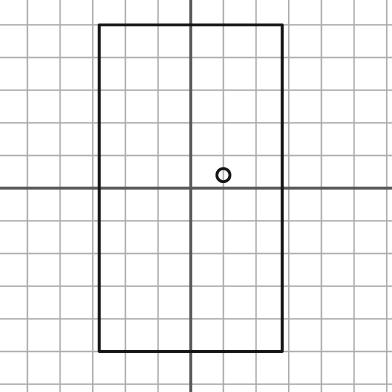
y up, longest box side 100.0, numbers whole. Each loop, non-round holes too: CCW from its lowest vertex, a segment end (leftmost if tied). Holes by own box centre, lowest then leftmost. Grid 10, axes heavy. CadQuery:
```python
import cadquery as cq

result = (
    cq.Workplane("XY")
    .moveTo(-28.0, -50.0)
    .lineTo(28.0, -50.0)
    .lineTo(28.0, 50.0)
    .lineTo(-28.0, 50.0)
    .close()
    .moveTo(10.0, 4.0)
    .circle(2.0)
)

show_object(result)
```